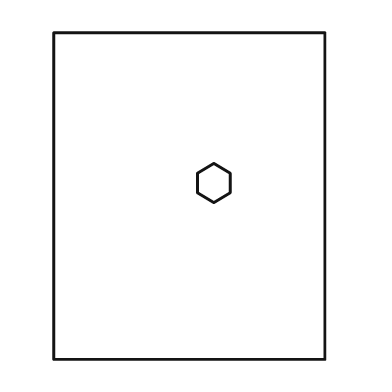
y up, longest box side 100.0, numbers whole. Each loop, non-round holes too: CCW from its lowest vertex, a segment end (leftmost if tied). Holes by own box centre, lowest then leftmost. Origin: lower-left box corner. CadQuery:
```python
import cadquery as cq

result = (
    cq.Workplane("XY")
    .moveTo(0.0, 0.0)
    .lineTo(83.0, 0.0)
    .lineTo(83.0, 100.0)
    .lineTo(0.0, 100.0)
    .close()
    .moveTo(49.0, 48.0)
    .lineTo(54.0, 51.0)
    .lineTo(54.0, 57.0)
    .lineTo(49.0, 60.0)
    .lineTo(44.0, 57.0)
    .lineTo(44.0, 51.0)
    .close()
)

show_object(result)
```